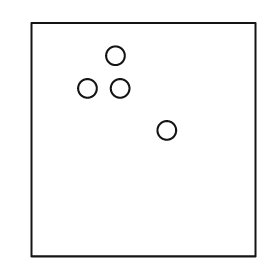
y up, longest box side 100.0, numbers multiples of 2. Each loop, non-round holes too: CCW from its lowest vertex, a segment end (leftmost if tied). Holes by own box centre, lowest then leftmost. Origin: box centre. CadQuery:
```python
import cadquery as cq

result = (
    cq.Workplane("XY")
    .moveTo(-48.0, -50.0)
    .lineTo(48.0, -50.0)
    .lineTo(48.0, 50.0)
    .lineTo(-48.0, 50.0)
    .close()
    .moveTo(10.0, 4.0)
    .circle(4.0)
    .moveTo(-24.0, 22.0)
    .circle(4.0)
    .moveTo(-10.0, 22.0)
    .circle(4.0)
    .moveTo(-12.0, 36.0)
    .circle(4.0)
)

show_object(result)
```